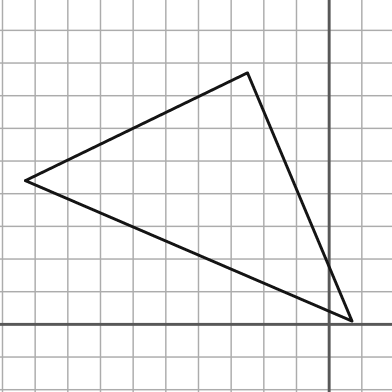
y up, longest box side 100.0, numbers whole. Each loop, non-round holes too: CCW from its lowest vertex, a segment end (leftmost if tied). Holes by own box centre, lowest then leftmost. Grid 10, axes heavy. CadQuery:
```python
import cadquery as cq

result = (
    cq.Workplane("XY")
    .moveTo(7.0, 1.0)
    .lineTo(-25.0, 77.0)
    .lineTo(-93.0, 44.0)
    .close()
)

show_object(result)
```